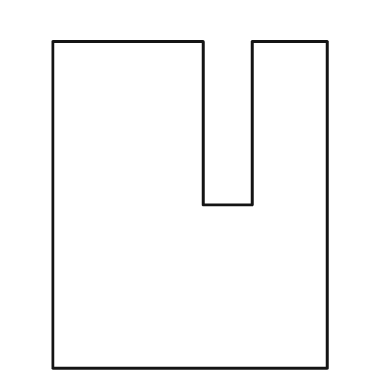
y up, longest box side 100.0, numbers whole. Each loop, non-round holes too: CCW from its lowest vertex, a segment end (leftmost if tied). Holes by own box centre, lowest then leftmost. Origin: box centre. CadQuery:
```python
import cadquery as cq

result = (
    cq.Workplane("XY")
    .moveTo(-42.0, -50.0)
    .lineTo(42.0, -50.0)
    .lineTo(42.0, 50.0)
    .lineTo(19.0, 50.0)
    .lineTo(19.0, 0.0)
    .lineTo(4.0, 0.0)
    .lineTo(4.0, 50.0)
    .lineTo(-42.0, 50.0)
    .close()
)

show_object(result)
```